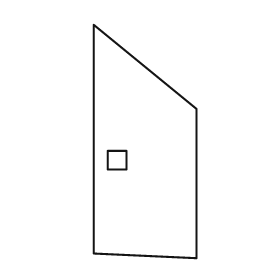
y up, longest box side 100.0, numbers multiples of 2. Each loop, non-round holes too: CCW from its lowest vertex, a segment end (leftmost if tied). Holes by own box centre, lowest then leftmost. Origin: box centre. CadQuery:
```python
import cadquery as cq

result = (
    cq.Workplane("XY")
    .moveTo(22.0, -50.0)
    .lineTo(22.0, 14.0)
    .lineTo(-22.0, 50.0)
    .lineTo(-22.0, -48.0)
    .close()
    .moveTo(-16.0, -12.0)
    .lineTo(-8.0, -12.0)
    .lineTo(-8.0, -4.0)
    .lineTo(-16.0, -4.0)
    .close()
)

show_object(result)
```